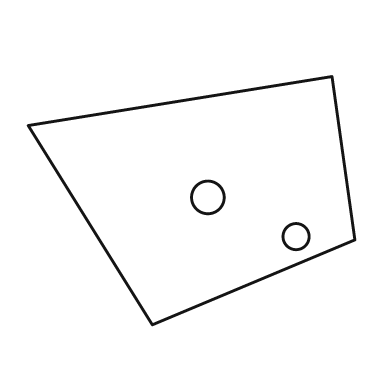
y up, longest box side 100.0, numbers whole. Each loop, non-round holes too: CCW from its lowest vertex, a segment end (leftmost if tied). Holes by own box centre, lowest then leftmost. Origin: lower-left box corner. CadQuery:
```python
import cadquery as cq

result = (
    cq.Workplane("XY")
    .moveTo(38.0, 0.0)
    .lineTo(100.0, 26.0)
    .lineTo(93.0, 76.0)
    .lineTo(0.0, 61.0)
    .close()
    .moveTo(82.0, 27.0)
    .circle(4.0)
    .moveTo(55.0, 39.0)
    .circle(5.0)
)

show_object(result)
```